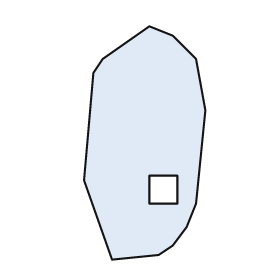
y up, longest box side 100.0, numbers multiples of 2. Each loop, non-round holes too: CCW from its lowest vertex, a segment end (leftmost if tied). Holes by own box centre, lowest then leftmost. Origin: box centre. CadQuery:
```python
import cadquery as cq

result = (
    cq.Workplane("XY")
    .moveTo(-14.0, -50.0)
    .lineTo(6.0, -48.0)
    .lineTo(12.0, -44.0)
    .lineTo(18.0, -36.0)
    .lineTo(22.0, -26.0)
    .lineTo(26.0, 14.0)
    .lineTo(22.0, 36.0)
    .lineTo(12.0, 46.0)
    .lineTo(2.0, 50.0)
    .lineTo(-18.0, 36.0)
    .lineTo(-22.0, 30.0)
    .lineTo(-26.0, -16.0)
    .close()
    .moveTo(2.0, -26.0)
    .lineTo(14.0, -26.0)
    .lineTo(14.0, -14.0)
    .lineTo(2.0, -14.0)
    .close()
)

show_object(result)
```